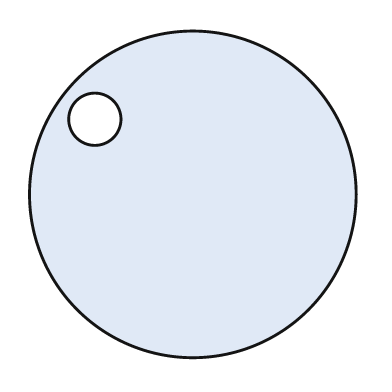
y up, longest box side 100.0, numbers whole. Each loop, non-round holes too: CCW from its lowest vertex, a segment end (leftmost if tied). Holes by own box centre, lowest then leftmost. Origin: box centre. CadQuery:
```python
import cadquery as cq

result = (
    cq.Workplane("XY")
    .moveTo(0.0, 0.0)
    .circle(50.0)
    .moveTo(-30.0, 23.0)
    .circle(8.0)
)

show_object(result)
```